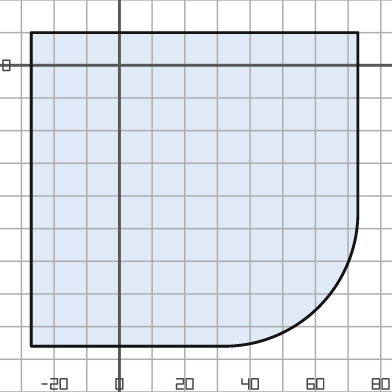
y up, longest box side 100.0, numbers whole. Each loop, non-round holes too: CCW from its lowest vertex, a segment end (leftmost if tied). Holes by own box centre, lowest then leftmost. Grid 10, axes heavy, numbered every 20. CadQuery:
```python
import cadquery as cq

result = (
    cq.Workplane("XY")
    .moveTo(-27.0, -86.0)
    .lineTo(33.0, -86.0)
    .threePointArc((61.0, -74.0), (73.0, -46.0))
    .lineTo(73.0, 10.0)
    .lineTo(-27.0, 10.0)
    .close()
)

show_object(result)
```